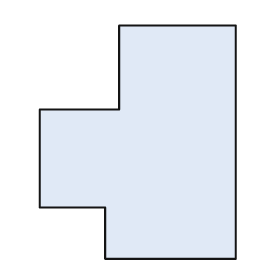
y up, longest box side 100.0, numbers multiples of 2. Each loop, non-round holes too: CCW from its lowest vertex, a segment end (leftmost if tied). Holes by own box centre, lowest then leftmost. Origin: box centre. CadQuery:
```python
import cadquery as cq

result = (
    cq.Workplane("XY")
    .moveTo(-14.0, -50.0)
    .lineTo(42.0, -50.0)
    .lineTo(42.0, 50.0)
    .lineTo(-8.0, 50.0)
    .lineTo(-8.0, 14.0)
    .lineTo(-42.0, 14.0)
    .lineTo(-42.0, -28.0)
    .lineTo(-14.0, -28.0)
    .close()
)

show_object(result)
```